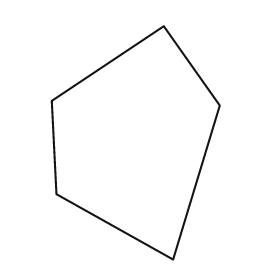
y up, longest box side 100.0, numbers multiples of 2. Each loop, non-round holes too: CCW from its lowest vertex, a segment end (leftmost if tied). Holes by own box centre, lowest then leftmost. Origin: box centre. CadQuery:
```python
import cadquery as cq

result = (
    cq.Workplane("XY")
    .moveTo(16.0, -50.0)
    .lineTo(36.0, 16.0)
    .lineTo(12.0, 50.0)
    .lineTo(-36.0, 18.0)
    .lineTo(-34.0, -22.0)
    .close()
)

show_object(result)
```